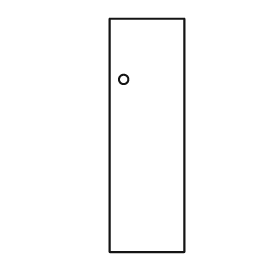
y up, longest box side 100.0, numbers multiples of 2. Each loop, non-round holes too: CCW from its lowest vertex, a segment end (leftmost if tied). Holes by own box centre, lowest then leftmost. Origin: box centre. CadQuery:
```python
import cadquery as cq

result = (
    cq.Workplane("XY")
    .moveTo(-16.0, -50.0)
    .lineTo(16.0, -50.0)
    .lineTo(16.0, 50.0)
    .lineTo(-16.0, 50.0)
    .close()
    .moveTo(-10.0, 24.0)
    .circle(2.0)
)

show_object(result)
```